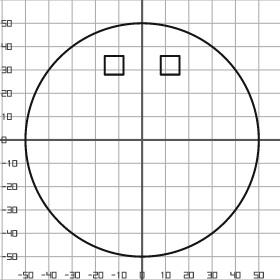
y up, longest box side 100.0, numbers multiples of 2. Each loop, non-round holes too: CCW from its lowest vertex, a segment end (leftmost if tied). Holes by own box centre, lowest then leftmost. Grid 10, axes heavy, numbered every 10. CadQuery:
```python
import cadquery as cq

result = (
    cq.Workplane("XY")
    .moveTo(0.0, 0.0)
    .circle(50.0)
    .moveTo(-16.0, 28.0)
    .lineTo(-8.0, 28.0)
    .lineTo(-8.0, 36.0)
    .lineTo(-16.0, 36.0)
    .close()
    .moveTo(8.0, 28.0)
    .lineTo(16.0, 28.0)
    .lineTo(16.0, 36.0)
    .lineTo(8.0, 36.0)
    .close()
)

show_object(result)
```